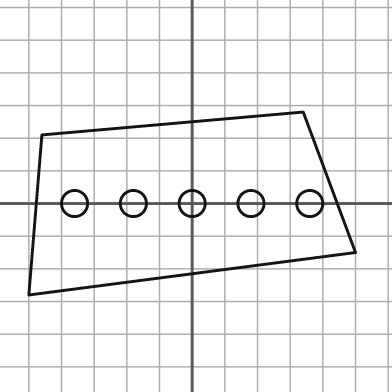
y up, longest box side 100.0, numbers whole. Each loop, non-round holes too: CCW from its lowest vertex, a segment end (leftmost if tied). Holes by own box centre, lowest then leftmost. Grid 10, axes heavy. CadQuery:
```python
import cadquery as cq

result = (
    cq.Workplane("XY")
    .moveTo(-50.0, -28.0)
    .lineTo(50.0, -15.0)
    .lineTo(34.0, 28.0)
    .lineTo(-46.0, 21.0)
    .close()
    .moveTo(-36.0, 0.0)
    .circle(4.0)
    .moveTo(-18.0, 0.0)
    .circle(4.0)
    .moveTo(0.0, 0.0)
    .circle(4.0)
    .moveTo(18.0, 0.0)
    .circle(4.0)
    .moveTo(36.0, 0.0)
    .circle(4.0)
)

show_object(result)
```